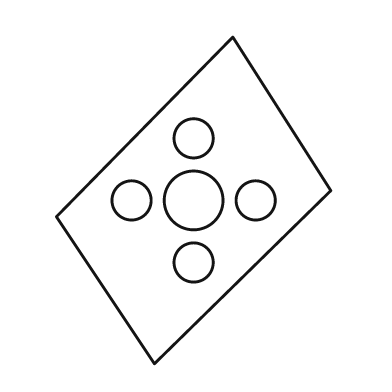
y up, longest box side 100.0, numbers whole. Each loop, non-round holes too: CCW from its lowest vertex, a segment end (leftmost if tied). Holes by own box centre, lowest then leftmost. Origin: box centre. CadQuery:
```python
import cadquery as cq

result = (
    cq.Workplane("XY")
    .moveTo(-12.0, -50.0)
    .lineTo(42.0, 3.0)
    .lineTo(12.0, 50.0)
    .lineTo(-42.0, -5.0)
    .close()
    .moveTo(0.0, -19.0)
    .circle(6.0)
    .moveTo(-19.0, 0.0)
    .circle(6.0)
    .moveTo(0.0, 0.0)
    .circle(9.0)
    .moveTo(19.0, 0.0)
    .circle(6.0)
    .moveTo(0.0, 19.0)
    .circle(6.0)
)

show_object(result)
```